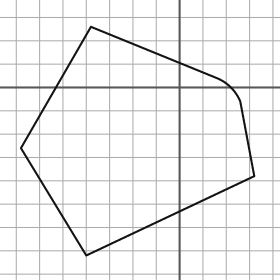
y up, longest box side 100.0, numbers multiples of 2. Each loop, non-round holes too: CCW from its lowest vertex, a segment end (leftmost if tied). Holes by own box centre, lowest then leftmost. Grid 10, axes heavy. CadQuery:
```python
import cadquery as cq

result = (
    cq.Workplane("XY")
    .moveTo(-40.0, -72.0)
    .lineTo(32.0, -38.0)
    .lineTo(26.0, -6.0)
    .threePointArc((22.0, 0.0), (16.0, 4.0))
    .lineTo(-38.0, 26.0)
    .lineTo(-68.0, -26.0)
    .close()
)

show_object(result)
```